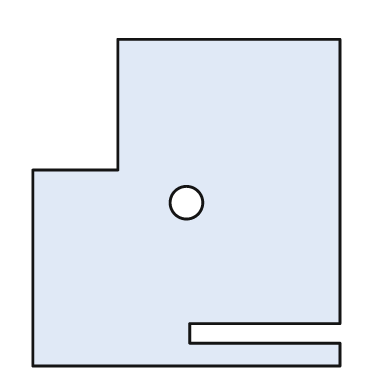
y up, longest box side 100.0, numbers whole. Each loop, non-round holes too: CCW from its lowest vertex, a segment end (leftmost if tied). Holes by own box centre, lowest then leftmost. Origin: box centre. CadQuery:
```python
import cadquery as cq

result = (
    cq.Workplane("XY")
    .moveTo(-47.0, -50.0)
    .lineTo(47.0, -50.0)
    .lineTo(47.0, -43.0)
    .lineTo(1.0, -43.0)
    .lineTo(1.0, -37.0)
    .lineTo(47.0, -37.0)
    .lineTo(47.0, 50.0)
    .lineTo(-21.0, 50.0)
    .lineTo(-21.0, 10.0)
    .lineTo(-47.0, 10.0)
    .close()
    .moveTo(0.0, 0.0)
    .circle(5.0)
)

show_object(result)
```